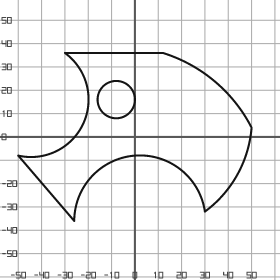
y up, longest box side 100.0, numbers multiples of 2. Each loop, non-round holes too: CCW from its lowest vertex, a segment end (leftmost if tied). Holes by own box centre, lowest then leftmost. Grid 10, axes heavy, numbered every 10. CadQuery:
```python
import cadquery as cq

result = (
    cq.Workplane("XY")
    .moveTo(-26.0, -36.0)
    .threePointArc((0.0, -8.0), (30.0, -32.0))
    .threePointArc((44.0, -16.0), (50.0, 4.0))
    .threePointArc((34.0, 24.0), (12.0, 36.0))
    .lineTo(-30.0, 36.0)
    .threePointArc((-22.0, 6.0), (-50.0, -8.0))
    .close()
    .moveTo(-8.0, 16.0)
    .circle(8.0)
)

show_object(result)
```